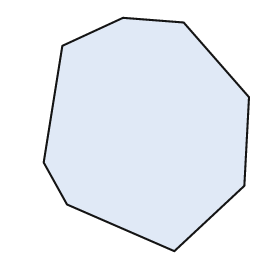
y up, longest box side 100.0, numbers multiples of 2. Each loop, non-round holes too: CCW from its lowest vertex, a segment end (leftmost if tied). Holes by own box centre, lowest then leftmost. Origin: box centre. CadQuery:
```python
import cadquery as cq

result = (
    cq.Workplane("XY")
    .moveTo(12.0, -50.0)
    .lineTo(42.0, -22.0)
    .lineTo(44.0, 16.0)
    .lineTo(16.0, 48.0)
    .lineTo(-10.0, 50.0)
    .lineTo(-36.0, 38.0)
    .lineTo(-44.0, -12.0)
    .lineTo(-34.0, -30.0)
    .close()
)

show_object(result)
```